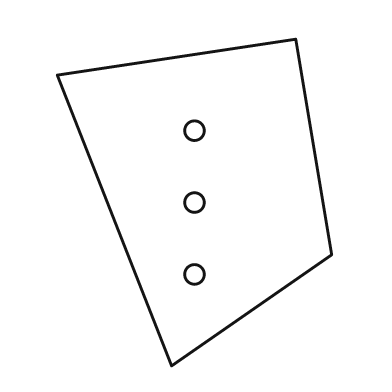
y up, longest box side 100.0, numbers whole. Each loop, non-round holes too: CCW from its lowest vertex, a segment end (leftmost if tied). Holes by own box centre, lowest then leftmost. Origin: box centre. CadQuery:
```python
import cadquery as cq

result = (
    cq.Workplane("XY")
    .moveTo(-7.0, -50.0)
    .lineTo(42.0, -16.0)
    .lineTo(31.0, 50.0)
    .lineTo(-42.0, 39.0)
    .close()
    .moveTo(0.0, -22.0)
    .circle(3.0)
    .moveTo(0.0, 0.0)
    .circle(3.0)
    .moveTo(0.0, 22.0)
    .circle(3.0)
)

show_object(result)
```